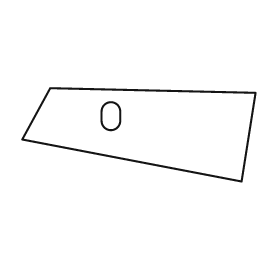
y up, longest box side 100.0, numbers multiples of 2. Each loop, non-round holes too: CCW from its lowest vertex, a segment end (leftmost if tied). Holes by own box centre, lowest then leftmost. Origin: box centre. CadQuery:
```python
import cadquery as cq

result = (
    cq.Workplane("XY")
    .moveTo(44.0, -20.0)
    .lineTo(50.0, 18.0)
    .lineTo(-38.0, 20.0)
    .lineTo(-50.0, -2.0)
    .close()
    .moveTo(-16.0, 6.0)
    .threePointArc((-12.0, 2.0), (-8.0, 6.0))
    .lineTo(-8.0, 10.0)
    .threePointArc((-12.0, 14.0), (-16.0, 10.0))
    .close()
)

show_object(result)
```